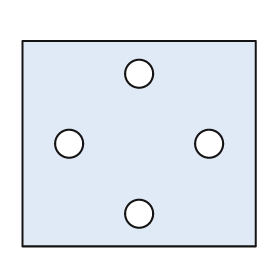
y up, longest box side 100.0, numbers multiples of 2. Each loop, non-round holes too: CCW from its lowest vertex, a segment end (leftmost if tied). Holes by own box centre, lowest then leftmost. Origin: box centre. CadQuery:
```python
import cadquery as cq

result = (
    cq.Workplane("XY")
    .moveTo(-50.0, -44.0)
    .lineTo(50.0, -44.0)
    .lineTo(50.0, 44.0)
    .lineTo(-50.0, 44.0)
    .close()
    .moveTo(0.0, -30.0)
    .circle(6.0)
    .moveTo(-30.0, 0.0)
    .circle(6.0)
    .moveTo(30.0, 0.0)
    .circle(6.0)
    .moveTo(0.0, 30.0)
    .circle(6.0)
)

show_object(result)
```